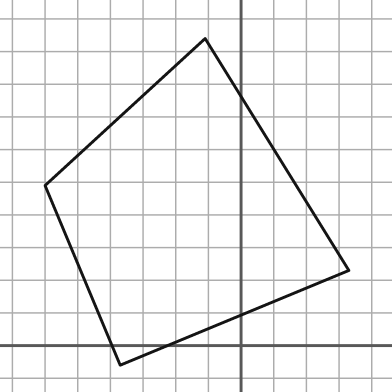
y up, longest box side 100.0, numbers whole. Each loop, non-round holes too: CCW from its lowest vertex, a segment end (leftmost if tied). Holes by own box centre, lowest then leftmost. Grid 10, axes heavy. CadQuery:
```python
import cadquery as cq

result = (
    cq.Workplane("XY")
    .moveTo(-37.0, -6.0)
    .lineTo(33.0, 23.0)
    .lineTo(-11.0, 94.0)
    .lineTo(-60.0, 49.0)
    .close()
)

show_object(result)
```